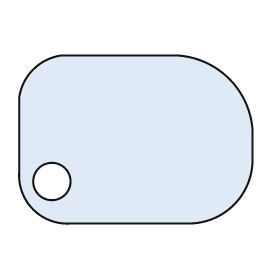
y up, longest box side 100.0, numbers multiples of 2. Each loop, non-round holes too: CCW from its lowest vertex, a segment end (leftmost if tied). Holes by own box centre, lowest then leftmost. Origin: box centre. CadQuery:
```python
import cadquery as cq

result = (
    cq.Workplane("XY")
    .moveTo(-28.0, -36.0)
    .lineTo(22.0, -36.0)
    .threePointArc((42.0, -28.0), (50.0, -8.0))
    .lineTo(50.0, 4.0)
    .threePointArc((40.0, 26.0), (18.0, 36.0))
    .lineTo(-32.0, 36.0)
    .threePointArc((-44.0, 30.0), (-50.0, 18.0))
    .lineTo(-50.0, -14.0)
    .threePointArc((-44.0, -30.0), (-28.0, -36.0))
    .close()
    .moveTo(-36.0, -18.0)
    .circle(8.0)
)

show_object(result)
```